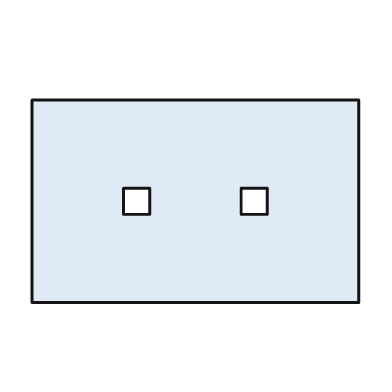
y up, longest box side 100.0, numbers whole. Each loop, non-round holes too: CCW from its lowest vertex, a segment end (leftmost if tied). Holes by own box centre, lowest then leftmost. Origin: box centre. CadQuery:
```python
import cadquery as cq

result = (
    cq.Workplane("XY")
    .moveTo(-50.0, -31.0)
    .lineTo(50.0, -31.0)
    .lineTo(50.0, 31.0)
    .lineTo(-50.0, 31.0)
    .close()
    .moveTo(-22.0, -4.0)
    .lineTo(-14.0, -4.0)
    .lineTo(-14.0, 4.0)
    .lineTo(-22.0, 4.0)
    .close()
    .moveTo(14.0, -4.0)
    .lineTo(22.0, -4.0)
    .lineTo(22.0, 4.0)
    .lineTo(14.0, 4.0)
    .close()
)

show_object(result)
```